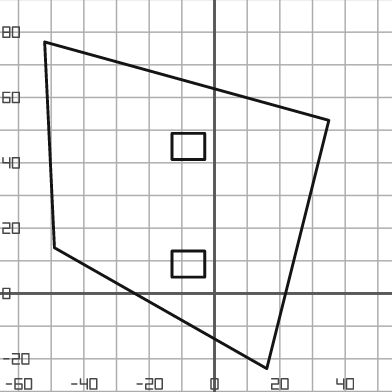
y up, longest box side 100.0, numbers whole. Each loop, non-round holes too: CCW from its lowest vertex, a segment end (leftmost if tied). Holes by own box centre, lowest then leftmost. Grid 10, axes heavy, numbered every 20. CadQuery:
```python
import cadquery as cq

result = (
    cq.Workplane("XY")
    .moveTo(16.0, -23.0)
    .lineTo(35.0, 53.0)
    .lineTo(-52.0, 77.0)
    .lineTo(-49.0, 14.0)
    .close()
    .moveTo(-13.0, 5.0)
    .lineTo(-3.0, 5.0)
    .lineTo(-3.0, 13.0)
    .lineTo(-13.0, 13.0)
    .close()
    .moveTo(-13.0, 41.0)
    .lineTo(-3.0, 41.0)
    .lineTo(-3.0, 49.0)
    .lineTo(-13.0, 49.0)
    .close()
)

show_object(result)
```